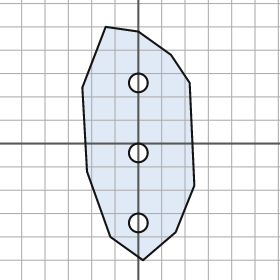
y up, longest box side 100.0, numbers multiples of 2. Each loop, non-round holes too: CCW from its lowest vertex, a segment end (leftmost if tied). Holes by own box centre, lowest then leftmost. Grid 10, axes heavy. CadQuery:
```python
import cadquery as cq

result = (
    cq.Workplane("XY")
    .moveTo(2.0, -50.0)
    .lineTo(16.0, -38.0)
    .lineTo(24.0, -18.0)
    .lineTo(22.0, 26.0)
    .lineTo(14.0, 38.0)
    .lineTo(0.0, 48.0)
    .lineTo(-14.0, 50.0)
    .lineTo(-24.0, 24.0)
    .lineTo(-22.0, -12.0)
    .lineTo(-12.0, -40.0)
    .close()
    .moveTo(0.0, -34.0)
    .circle(4.0)
    .moveTo(0.0, -4.0)
    .circle(4.0)
    .moveTo(0.0, 26.0)
    .circle(4.0)
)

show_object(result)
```